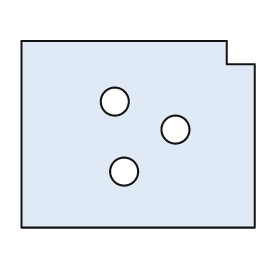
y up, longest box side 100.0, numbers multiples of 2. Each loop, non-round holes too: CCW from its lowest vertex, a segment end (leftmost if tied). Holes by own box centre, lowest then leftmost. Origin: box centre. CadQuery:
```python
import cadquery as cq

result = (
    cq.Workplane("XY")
    .moveTo(-50.0, -40.0)
    .lineTo(50.0, -40.0)
    .lineTo(50.0, 30.0)
    .lineTo(38.0, 30.0)
    .lineTo(38.0, 40.0)
    .lineTo(-50.0, 40.0)
    .close()
    .moveTo(-6.0, -16.0)
    .circle(6.0)
    .moveTo(16.0, 2.0)
    .circle(6.0)
    .moveTo(-10.0, 14.0)
    .circle(6.0)
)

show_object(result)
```